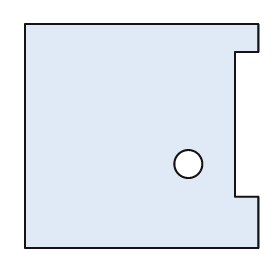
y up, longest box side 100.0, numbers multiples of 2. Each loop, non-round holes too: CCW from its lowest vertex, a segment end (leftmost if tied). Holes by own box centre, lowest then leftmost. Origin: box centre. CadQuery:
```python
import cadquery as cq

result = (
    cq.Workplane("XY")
    .moveTo(-50.0, -48.0)
    .lineTo(50.0, -48.0)
    .lineTo(50.0, -26.0)
    .lineTo(40.0, -26.0)
    .lineTo(40.0, 36.0)
    .lineTo(50.0, 36.0)
    .lineTo(50.0, 48.0)
    .lineTo(-50.0, 48.0)
    .close()
    .moveTo(20.0, -12.0)
    .circle(6.0)
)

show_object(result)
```